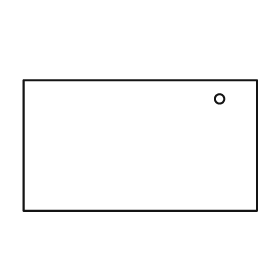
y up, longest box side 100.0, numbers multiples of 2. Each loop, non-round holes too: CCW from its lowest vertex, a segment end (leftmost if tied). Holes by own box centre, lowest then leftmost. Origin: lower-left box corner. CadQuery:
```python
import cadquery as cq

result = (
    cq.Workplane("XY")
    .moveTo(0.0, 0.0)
    .lineTo(100.0, 0.0)
    .lineTo(100.0, 56.0)
    .lineTo(0.0, 56.0)
    .close()
    .moveTo(84.0, 48.0)
    .circle(2.0)
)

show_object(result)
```